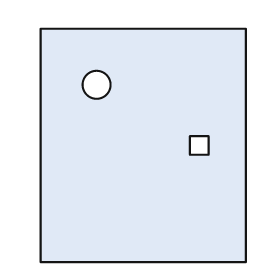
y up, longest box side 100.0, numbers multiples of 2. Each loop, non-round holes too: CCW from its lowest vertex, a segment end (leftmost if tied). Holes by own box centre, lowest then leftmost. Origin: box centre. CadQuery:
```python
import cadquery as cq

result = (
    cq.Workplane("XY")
    .moveTo(-44.0, -50.0)
    .lineTo(44.0, -50.0)
    .lineTo(44.0, 50.0)
    .lineTo(-44.0, 50.0)
    .close()
    .moveTo(20.0, -4.0)
    .lineTo(28.0, -4.0)
    .lineTo(28.0, 4.0)
    .lineTo(20.0, 4.0)
    .close()
    .moveTo(-20.0, 26.0)
    .circle(6.0)
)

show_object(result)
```